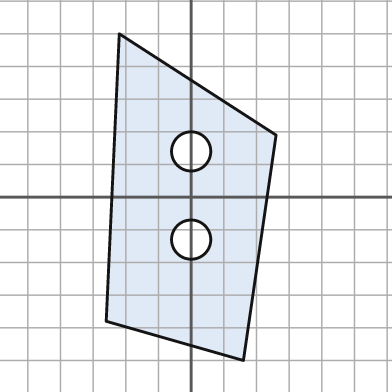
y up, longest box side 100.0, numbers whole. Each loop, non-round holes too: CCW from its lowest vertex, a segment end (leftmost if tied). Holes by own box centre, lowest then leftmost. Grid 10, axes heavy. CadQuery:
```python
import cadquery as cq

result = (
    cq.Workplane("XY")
    .moveTo(16.0, -50.0)
    .lineTo(26.0, 19.0)
    .lineTo(-22.0, 50.0)
    .lineTo(-26.0, -38.0)
    .close()
    .moveTo(0.0, -13.0)
    .circle(6.0)
    .moveTo(0.0, 14.0)
    .circle(6.0)
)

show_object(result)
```